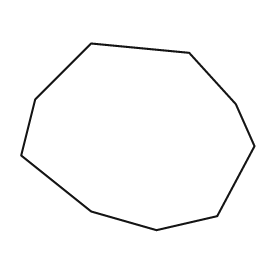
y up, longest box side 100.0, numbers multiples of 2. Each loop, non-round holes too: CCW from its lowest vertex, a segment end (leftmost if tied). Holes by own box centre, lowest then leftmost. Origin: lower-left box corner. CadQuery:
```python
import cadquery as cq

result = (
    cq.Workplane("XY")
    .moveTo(58.0, 0.0)
    .lineTo(84.0, 6.0)
    .lineTo(100.0, 36.0)
    .lineTo(92.0, 54.0)
    .lineTo(72.0, 76.0)
    .lineTo(30.0, 80.0)
    .lineTo(6.0, 56.0)
    .lineTo(0.0, 32.0)
    .lineTo(30.0, 8.0)
    .close()
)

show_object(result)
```